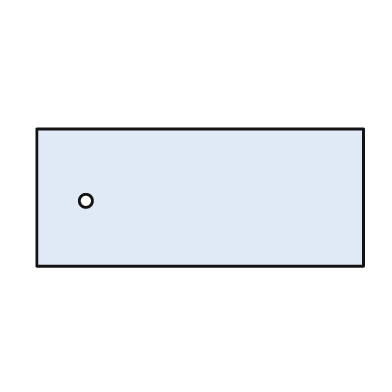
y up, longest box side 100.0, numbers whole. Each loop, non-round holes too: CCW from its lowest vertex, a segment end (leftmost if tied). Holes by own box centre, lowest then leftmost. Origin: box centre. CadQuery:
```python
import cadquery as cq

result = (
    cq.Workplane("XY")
    .moveTo(-50.0, -21.0)
    .lineTo(50.0, -21.0)
    .lineTo(50.0, 21.0)
    .lineTo(-50.0, 21.0)
    .close()
    .moveTo(-35.0, -1.0)
    .circle(2.0)
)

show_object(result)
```